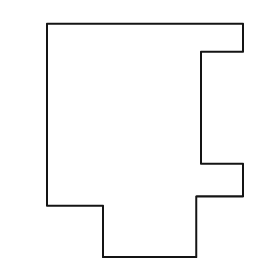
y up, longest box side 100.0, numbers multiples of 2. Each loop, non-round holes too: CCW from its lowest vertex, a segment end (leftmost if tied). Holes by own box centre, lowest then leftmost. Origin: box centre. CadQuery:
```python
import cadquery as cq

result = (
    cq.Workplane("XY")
    .moveTo(-18.0, -50.0)
    .lineTo(22.0, -50.0)
    .lineTo(22.0, -24.0)
    .lineTo(42.0, -24.0)
    .lineTo(42.0, -10.0)
    .lineTo(24.0, -10.0)
    .lineTo(24.0, 38.0)
    .lineTo(42.0, 38.0)
    .lineTo(42.0, 50.0)
    .lineTo(-42.0, 50.0)
    .lineTo(-42.0, -28.0)
    .lineTo(-18.0, -28.0)
    .close()
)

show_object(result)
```